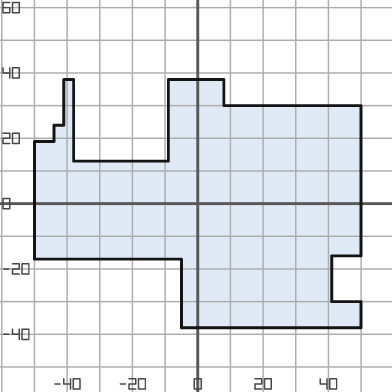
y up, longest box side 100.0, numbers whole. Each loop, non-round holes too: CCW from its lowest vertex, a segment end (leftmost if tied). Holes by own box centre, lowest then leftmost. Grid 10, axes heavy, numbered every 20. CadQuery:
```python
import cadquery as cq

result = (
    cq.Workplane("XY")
    .moveTo(-5.0, -38.0)
    .lineTo(50.0, -38.0)
    .lineTo(50.0, -30.0)
    .lineTo(41.0, -30.0)
    .lineTo(41.0, -16.0)
    .lineTo(50.0, -16.0)
    .lineTo(50.0, 30.0)
    .lineTo(8.0, 30.0)
    .lineTo(8.0, 38.0)
    .lineTo(-9.0, 38.0)
    .lineTo(-9.0, 13.0)
    .lineTo(-38.0, 13.0)
    .lineTo(-38.0, 38.0)
    .lineTo(-41.0, 38.0)
    .lineTo(-41.0, 24.0)
    .lineTo(-44.0, 24.0)
    .lineTo(-44.0, 19.0)
    .lineTo(-50.0, 19.0)
    .lineTo(-50.0, -17.0)
    .lineTo(-5.0, -17.0)
    .close()
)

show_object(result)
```